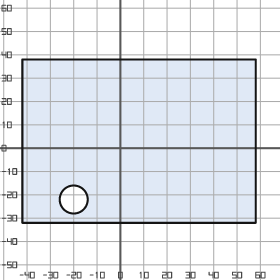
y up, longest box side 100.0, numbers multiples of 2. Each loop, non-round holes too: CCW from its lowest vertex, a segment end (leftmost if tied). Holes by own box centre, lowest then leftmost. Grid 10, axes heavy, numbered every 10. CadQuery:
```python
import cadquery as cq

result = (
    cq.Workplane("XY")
    .moveTo(-42.0, -32.0)
    .lineTo(58.0, -32.0)
    .lineTo(58.0, 38.0)
    .lineTo(-42.0, 38.0)
    .close()
    .moveTo(-20.0, -22.0)
    .circle(6.0)
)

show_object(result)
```